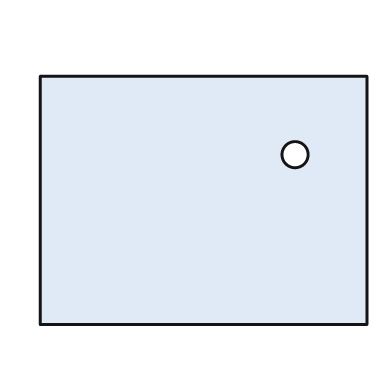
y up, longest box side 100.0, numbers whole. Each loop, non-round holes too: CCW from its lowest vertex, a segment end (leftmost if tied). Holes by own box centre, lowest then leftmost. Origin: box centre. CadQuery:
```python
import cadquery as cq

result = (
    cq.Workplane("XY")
    .moveTo(-50.0, -38.0)
    .lineTo(50.0, -38.0)
    .lineTo(50.0, 38.0)
    .lineTo(-50.0, 38.0)
    .close()
    .moveTo(28.0, 14.0)
    .circle(4.0)
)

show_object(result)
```